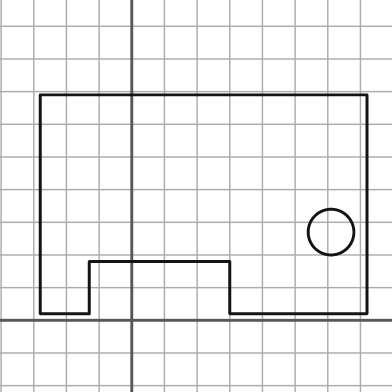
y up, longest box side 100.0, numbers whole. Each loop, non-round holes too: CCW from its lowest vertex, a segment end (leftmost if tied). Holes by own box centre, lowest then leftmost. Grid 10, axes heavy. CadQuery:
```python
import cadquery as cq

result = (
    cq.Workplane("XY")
    .moveTo(-28.0, 2.0)
    .lineTo(-13.0, 2.0)
    .lineTo(-13.0, 18.0)
    .lineTo(30.0, 18.0)
    .lineTo(30.0, 2.0)
    .lineTo(72.0, 2.0)
    .lineTo(72.0, 69.0)
    .lineTo(-28.0, 69.0)
    .close()
    .moveTo(61.0, 27.0)
    .circle(7.0)
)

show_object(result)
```